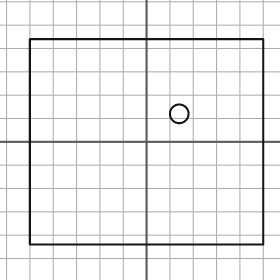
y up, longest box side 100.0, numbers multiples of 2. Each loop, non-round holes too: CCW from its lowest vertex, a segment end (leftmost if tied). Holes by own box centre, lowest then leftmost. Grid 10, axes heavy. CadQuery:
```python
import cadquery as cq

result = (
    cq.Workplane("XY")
    .moveTo(-50.0, -44.0)
    .lineTo(50.0, -44.0)
    .lineTo(50.0, 44.0)
    .lineTo(-50.0, 44.0)
    .close()
    .moveTo(14.0, 12.0)
    .circle(4.0)
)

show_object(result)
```